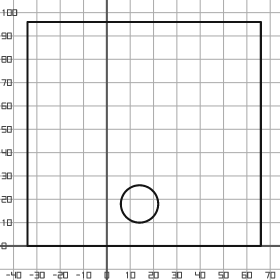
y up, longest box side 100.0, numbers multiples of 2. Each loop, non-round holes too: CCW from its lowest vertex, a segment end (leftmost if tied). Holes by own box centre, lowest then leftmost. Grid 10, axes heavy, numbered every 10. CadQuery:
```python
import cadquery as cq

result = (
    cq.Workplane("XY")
    .moveTo(-34.0, 0.0)
    .lineTo(66.0, 0.0)
    .lineTo(66.0, 96.0)
    .lineTo(-34.0, 96.0)
    .close()
    .moveTo(14.0, 18.0)
    .circle(8.0)
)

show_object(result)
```